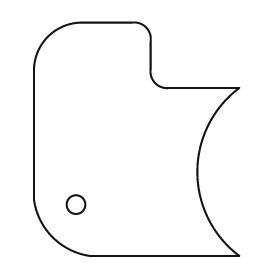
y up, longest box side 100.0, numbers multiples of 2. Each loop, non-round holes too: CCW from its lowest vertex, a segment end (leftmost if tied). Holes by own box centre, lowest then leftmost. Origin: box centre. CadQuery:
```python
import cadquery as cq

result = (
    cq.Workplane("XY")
    .moveTo(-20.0, -50.0)
    .lineTo(44.0, -50.0)
    .threePointArc((26.0, -14.0), (44.0, 22.0))
    .lineTo(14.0, 22.0)
    .threePointArc((8.0, 24.0), (6.0, 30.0))
    .lineTo(6.0, 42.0)
    .threePointArc((4.0, 48.0), (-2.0, 50.0))
    .lineTo(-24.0, 50.0)
    .threePointArc((-38.0, 44.0), (-44.0, 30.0))
    .lineTo(-44.0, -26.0)
    .threePointArc((-36.0, -42.0), (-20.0, -50.0))
    .close()
    .moveTo(-26.0, -28.0)
    .circle(4.0)
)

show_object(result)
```